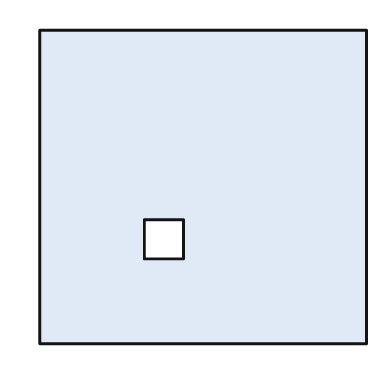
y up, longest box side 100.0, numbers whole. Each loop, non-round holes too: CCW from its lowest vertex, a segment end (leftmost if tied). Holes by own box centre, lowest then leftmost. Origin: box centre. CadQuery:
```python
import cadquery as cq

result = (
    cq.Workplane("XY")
    .moveTo(-50.0, -48.0)
    .lineTo(50.0, -48.0)
    .lineTo(50.0, 48.0)
    .lineTo(-50.0, 48.0)
    .close()
    .moveTo(-18.0, -22.0)
    .lineTo(-6.0, -22.0)
    .lineTo(-6.0, -10.0)
    .lineTo(-18.0, -10.0)
    .close()
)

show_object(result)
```